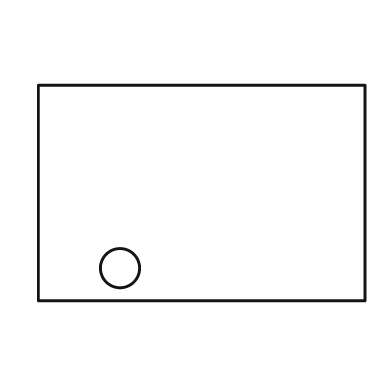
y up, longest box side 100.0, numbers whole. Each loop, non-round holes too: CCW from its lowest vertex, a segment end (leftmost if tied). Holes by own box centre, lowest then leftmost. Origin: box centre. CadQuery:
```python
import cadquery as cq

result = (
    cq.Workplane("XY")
    .moveTo(-50.0, -33.0)
    .lineTo(50.0, -33.0)
    .lineTo(50.0, 33.0)
    .lineTo(-50.0, 33.0)
    .close()
    .moveTo(-25.0, -23.0)
    .circle(6.0)
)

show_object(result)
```